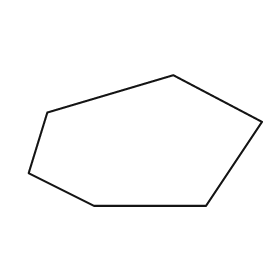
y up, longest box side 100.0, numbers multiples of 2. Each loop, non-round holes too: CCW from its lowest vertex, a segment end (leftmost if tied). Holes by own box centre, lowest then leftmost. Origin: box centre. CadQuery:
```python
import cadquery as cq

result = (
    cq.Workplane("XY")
    .moveTo(-22.0, -28.0)
    .lineTo(26.0, -28.0)
    .lineTo(50.0, 8.0)
    .lineTo(12.0, 28.0)
    .lineTo(-42.0, 12.0)
    .lineTo(-50.0, -14.0)
    .close()
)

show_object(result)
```